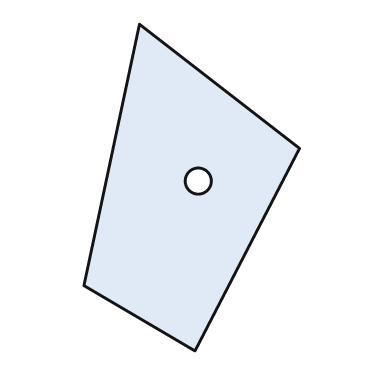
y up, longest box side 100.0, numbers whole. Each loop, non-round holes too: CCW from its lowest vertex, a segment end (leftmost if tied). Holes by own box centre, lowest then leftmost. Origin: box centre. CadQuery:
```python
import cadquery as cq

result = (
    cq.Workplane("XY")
    .moveTo(1.0, -50.0)
    .lineTo(33.0, 12.0)
    .lineTo(-16.0, 50.0)
    .lineTo(-33.0, -30.0)
    .close()
    .moveTo(2.0, 2.0)
    .circle(4.0)
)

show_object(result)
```